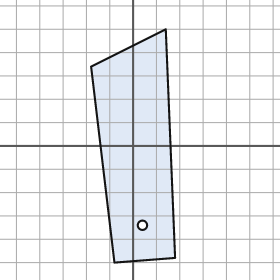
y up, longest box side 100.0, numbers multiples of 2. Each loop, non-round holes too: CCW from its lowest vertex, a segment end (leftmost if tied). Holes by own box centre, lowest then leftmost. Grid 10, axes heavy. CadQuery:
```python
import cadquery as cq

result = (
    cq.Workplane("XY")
    .moveTo(-8.0, -50.0)
    .lineTo(18.0, -48.0)
    .lineTo(14.0, 50.0)
    .lineTo(-18.0, 34.0)
    .close()
    .moveTo(4.0, -34.0)
    .circle(2.0)
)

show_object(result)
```